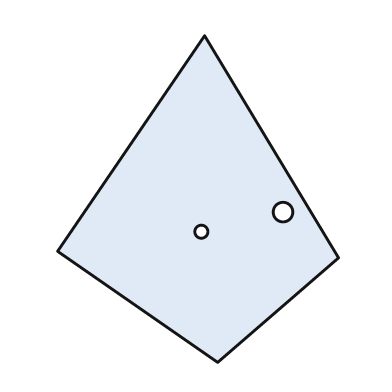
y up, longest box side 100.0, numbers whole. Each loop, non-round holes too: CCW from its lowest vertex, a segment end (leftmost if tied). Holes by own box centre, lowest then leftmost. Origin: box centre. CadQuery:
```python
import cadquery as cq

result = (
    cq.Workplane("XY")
    .moveTo(6.0, -50.0)
    .lineTo(43.0, -18.0)
    .lineTo(2.0, 50.0)
    .lineTo(-43.0, -16.0)
    .close()
    .moveTo(1.0, -10.0)
    .circle(2.0)
    .moveTo(26.0, -4.0)
    .circle(3.0)
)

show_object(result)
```